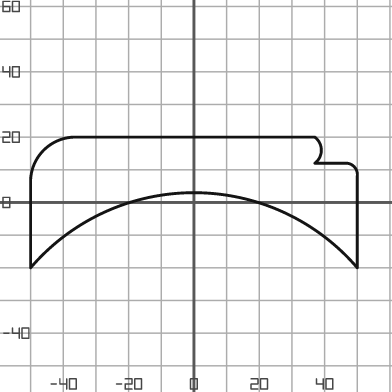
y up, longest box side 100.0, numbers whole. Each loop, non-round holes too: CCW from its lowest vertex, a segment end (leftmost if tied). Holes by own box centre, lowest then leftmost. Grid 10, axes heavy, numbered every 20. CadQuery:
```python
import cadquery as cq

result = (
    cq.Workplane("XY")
    .moveTo(-50.0, -20.0)
    .threePointArc((0.0, 3.0), (50.0, -20.0))
    .lineTo(50.0, 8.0)
    .threePointArc((49.0, 11.0), (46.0, 12.0))
    .lineTo(37.0, 12.0)
    .threePointArc((39.0, 16.0), (37.0, 20.0))
    .lineTo(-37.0, 20.0)
    .threePointArc((-46.0, 16.0), (-50.0, 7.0))
    .close()
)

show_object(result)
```